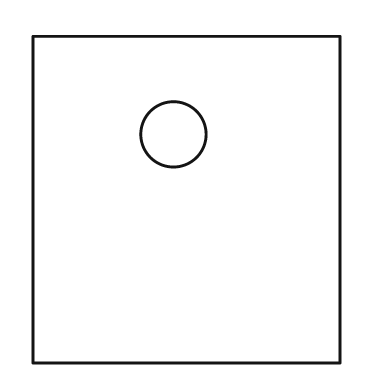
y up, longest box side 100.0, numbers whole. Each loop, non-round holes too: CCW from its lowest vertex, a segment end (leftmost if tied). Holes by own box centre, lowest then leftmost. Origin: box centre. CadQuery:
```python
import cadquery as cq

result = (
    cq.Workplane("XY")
    .moveTo(-47.0, -50.0)
    .lineTo(47.0, -50.0)
    .lineTo(47.0, 50.0)
    .lineTo(-47.0, 50.0)
    .close()
    .moveTo(-4.0, 20.0)
    .circle(10.0)
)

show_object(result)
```